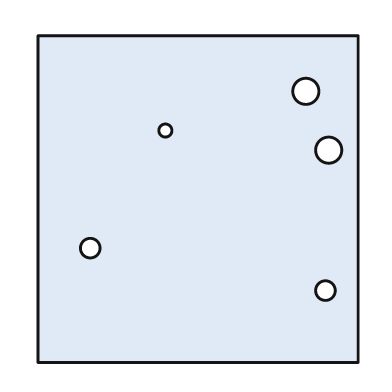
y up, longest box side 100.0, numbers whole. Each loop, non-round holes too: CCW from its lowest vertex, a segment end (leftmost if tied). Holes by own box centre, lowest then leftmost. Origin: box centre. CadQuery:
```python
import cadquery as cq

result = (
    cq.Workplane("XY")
    .moveTo(-49.0, -50.0)
    .lineTo(49.0, -50.0)
    .lineTo(49.0, 50.0)
    .lineTo(-49.0, 50.0)
    .close()
    .moveTo(39.0, -28.0)
    .circle(3.0)
    .moveTo(-33.0, -15.0)
    .circle(3.0)
    .moveTo(40.0, 15.0)
    .circle(4.0)
    .moveTo(-10.0, 21.0)
    .circle(2.0)
    .moveTo(33.0, 33.0)
    .circle(4.0)
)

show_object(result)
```